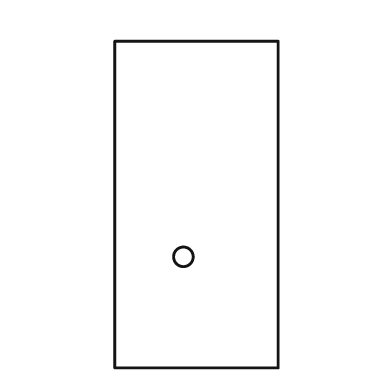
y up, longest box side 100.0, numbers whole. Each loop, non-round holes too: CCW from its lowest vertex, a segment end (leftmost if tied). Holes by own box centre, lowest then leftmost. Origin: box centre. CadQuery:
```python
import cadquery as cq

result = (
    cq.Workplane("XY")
    .moveTo(-25.0, -50.0)
    .lineTo(25.0, -50.0)
    .lineTo(25.0, 50.0)
    .lineTo(-25.0, 50.0)
    .close()
    .moveTo(-4.0, -16.0)
    .circle(3.0)
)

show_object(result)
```